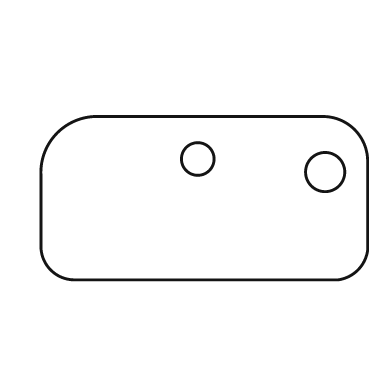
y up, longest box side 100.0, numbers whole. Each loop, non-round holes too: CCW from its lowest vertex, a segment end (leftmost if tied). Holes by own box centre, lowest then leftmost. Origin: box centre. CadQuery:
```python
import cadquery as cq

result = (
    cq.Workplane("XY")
    .moveTo(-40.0, -25.0)
    .lineTo(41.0, -25.0)
    .threePointArc((47.0, -22.0), (50.0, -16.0))
    .lineTo(50.0, 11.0)
    .threePointArc((46.0, 21.0), (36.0, 25.0))
    .lineTo(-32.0, 25.0)
    .threePointArc((-45.0, 20.0), (-50.0, 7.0))
    .lineTo(-50.0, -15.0)
    .threePointArc((-47.0, -22.0), (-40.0, -25.0))
    .close()
    .moveTo(37.0, 8.0)
    .circle(6.0)
    .moveTo(-2.0, 12.0)
    .circle(5.0)
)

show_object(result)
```